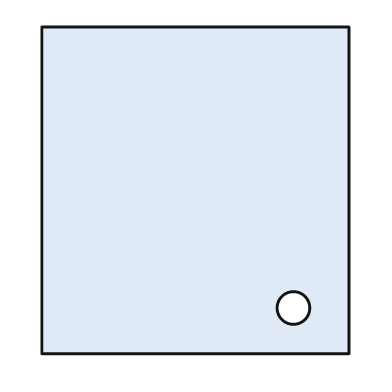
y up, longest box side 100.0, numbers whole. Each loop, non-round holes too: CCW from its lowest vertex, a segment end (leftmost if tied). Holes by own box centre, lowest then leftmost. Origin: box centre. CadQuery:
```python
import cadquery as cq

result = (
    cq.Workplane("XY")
    .moveTo(-47.0, -50.0)
    .lineTo(47.0, -50.0)
    .lineTo(47.0, 50.0)
    .lineTo(-47.0, 50.0)
    .close()
    .moveTo(30.0, -36.0)
    .circle(5.0)
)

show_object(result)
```